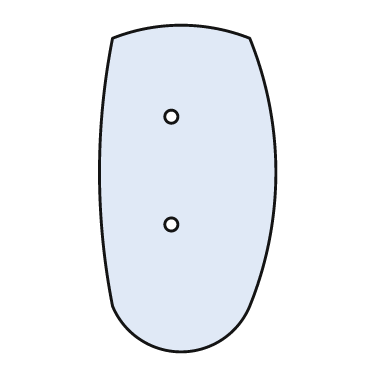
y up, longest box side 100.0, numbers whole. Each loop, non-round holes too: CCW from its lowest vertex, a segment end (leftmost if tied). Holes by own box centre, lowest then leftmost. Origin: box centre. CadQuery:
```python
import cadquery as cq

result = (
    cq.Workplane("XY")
    .moveTo(-23.0, -36.0)
    .threePointArc((-2.0, -50.0), (19.0, -36.0))
    .threePointArc((27.0, 5.0), (19.0, 46.0))
    .threePointArc((-2.0, 50.0), (-23.0, 46.0))
    .threePointArc((-27.0, 5.0), (-23.0, -36.0))
    .close()
    .moveTo(-5.0, -11.0)
    .circle(2.0)
    .moveTo(-5.0, 22.0)
    .circle(2.0)
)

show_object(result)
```